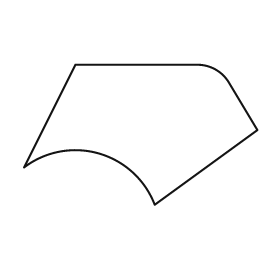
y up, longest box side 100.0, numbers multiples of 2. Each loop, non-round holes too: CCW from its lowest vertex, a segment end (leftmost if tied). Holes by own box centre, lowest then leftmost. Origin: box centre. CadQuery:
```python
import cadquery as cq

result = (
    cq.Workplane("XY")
    .moveTo(6.0, -30.0)
    .lineTo(50.0, 2.0)
    .lineTo(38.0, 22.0)
    .threePointArc((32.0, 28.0), (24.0, 30.0))
    .lineTo(-28.0, 30.0)
    .lineTo(-50.0, -14.0)
    .threePointArc((-18.0, -8.0), (6.0, -30.0))
    .close()
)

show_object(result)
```